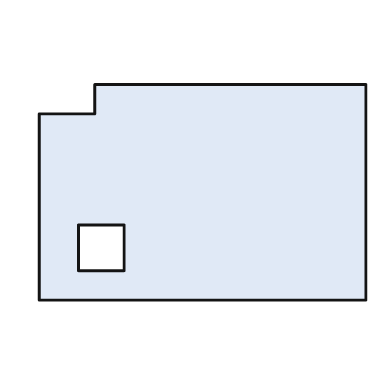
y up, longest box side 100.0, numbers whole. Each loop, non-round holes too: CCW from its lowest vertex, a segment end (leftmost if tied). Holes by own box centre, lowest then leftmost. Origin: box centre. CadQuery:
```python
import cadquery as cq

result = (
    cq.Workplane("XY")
    .moveTo(-50.0, -33.0)
    .lineTo(50.0, -33.0)
    .lineTo(50.0, 33.0)
    .lineTo(-33.0, 33.0)
    .lineTo(-33.0, 24.0)
    .lineTo(-50.0, 24.0)
    .close()
    .moveTo(-38.0, -24.0)
    .lineTo(-24.0, -24.0)
    .lineTo(-24.0, -10.0)
    .lineTo(-38.0, -10.0)
    .close()
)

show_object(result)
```